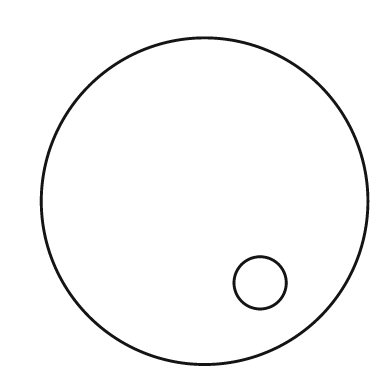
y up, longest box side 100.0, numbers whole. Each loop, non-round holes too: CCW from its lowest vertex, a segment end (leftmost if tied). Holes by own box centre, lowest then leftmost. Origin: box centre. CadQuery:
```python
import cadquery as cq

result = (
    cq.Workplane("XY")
    .moveTo(0.0, 0.0)
    .circle(50.0)
    .moveTo(17.0, -25.0)
    .circle(8.0)
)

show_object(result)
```